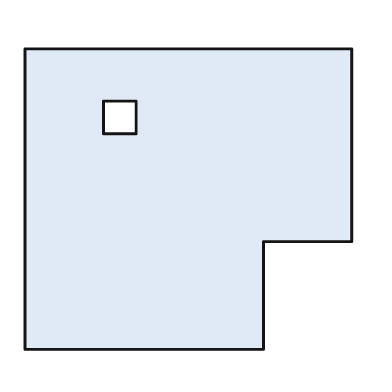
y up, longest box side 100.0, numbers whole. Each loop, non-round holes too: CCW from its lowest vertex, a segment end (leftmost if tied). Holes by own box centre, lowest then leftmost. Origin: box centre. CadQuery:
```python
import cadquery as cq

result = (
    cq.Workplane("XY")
    .moveTo(-50.0, -46.0)
    .lineTo(23.0, -46.0)
    .lineTo(23.0, -13.0)
    .lineTo(50.0, -13.0)
    .lineTo(50.0, 46.0)
    .lineTo(-50.0, 46.0)
    .close()
    .moveTo(-26.0, 20.0)
    .lineTo(-16.0, 20.0)
    .lineTo(-16.0, 30.0)
    .lineTo(-26.0, 30.0)
    .close()
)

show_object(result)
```